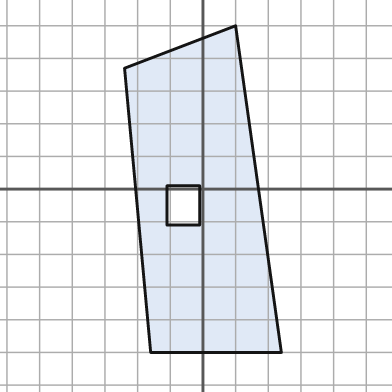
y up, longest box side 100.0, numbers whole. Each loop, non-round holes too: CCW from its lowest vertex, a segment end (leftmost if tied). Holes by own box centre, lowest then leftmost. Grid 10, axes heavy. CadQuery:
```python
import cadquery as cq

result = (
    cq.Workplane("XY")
    .moveTo(-16.0, -50.0)
    .lineTo(24.0, -50.0)
    .lineTo(10.0, 50.0)
    .lineTo(-24.0, 37.0)
    .close()
    .moveTo(-11.0, -11.0)
    .lineTo(-1.0, -11.0)
    .lineTo(-1.0, 1.0)
    .lineTo(-11.0, 1.0)
    .close()
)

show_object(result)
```